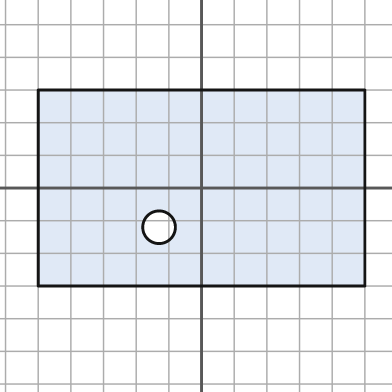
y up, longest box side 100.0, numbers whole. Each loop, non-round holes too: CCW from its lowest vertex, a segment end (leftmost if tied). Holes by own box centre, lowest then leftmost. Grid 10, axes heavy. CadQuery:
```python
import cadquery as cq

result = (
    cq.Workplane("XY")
    .moveTo(-50.0, -30.0)
    .lineTo(50.0, -30.0)
    .lineTo(50.0, 30.0)
    .lineTo(-50.0, 30.0)
    .close()
    .moveTo(-13.0, -12.0)
    .circle(5.0)
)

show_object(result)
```